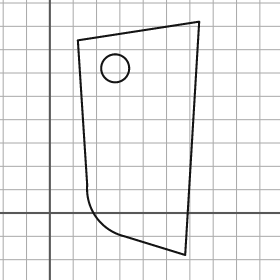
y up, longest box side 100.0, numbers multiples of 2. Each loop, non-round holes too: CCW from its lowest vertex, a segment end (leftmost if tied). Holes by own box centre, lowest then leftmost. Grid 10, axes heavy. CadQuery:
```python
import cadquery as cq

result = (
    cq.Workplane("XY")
    .moveTo(58.0, -18.0)
    .lineTo(64.0, 82.0)
    .lineTo(12.0, 74.0)
    .lineTo(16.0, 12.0)
    .threePointArc((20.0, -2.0), (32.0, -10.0))
    .close()
    .moveTo(28.0, 62.0)
    .circle(6.0)
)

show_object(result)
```